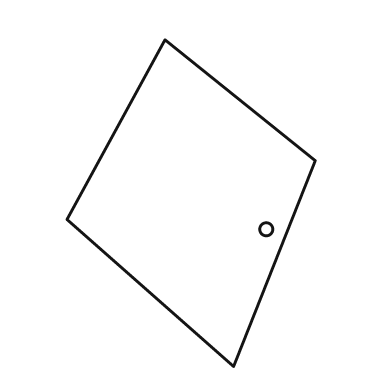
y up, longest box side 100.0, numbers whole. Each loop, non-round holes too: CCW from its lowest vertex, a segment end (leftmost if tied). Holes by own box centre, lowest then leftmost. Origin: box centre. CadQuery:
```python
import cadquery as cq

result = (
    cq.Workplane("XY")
    .moveTo(13.0, -50.0)
    .lineTo(38.0, 13.0)
    .lineTo(-8.0, 50.0)
    .lineTo(-38.0, -5.0)
    .close()
    .moveTo(23.0, -8.0)
    .circle(2.0)
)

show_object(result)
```